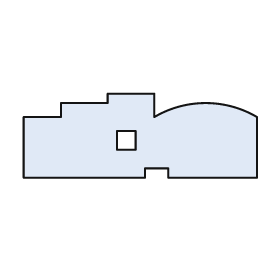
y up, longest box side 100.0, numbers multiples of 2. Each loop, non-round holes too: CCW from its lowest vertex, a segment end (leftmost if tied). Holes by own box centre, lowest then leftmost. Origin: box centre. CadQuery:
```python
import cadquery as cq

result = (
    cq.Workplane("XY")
    .moveTo(-50.0, -18.0)
    .lineTo(2.0, -18.0)
    .lineTo(2.0, -14.0)
    .lineTo(12.0, -14.0)
    .lineTo(12.0, -18.0)
    .lineTo(50.0, -18.0)
    .lineTo(50.0, 8.0)
    .threePointArc((28.0, 14.0), (6.0, 8.0))
    .lineTo(6.0, 18.0)
    .lineTo(-14.0, 18.0)
    .lineTo(-14.0, 14.0)
    .lineTo(-34.0, 14.0)
    .lineTo(-34.0, 8.0)
    .lineTo(-50.0, 8.0)
    .close()
    .moveTo(-10.0, -6.0)
    .lineTo(-2.0, -6.0)
    .lineTo(-2.0, 2.0)
    .lineTo(-10.0, 2.0)
    .close()
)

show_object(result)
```